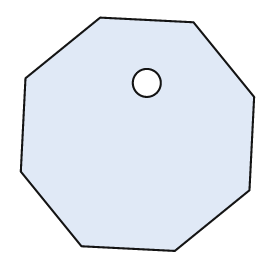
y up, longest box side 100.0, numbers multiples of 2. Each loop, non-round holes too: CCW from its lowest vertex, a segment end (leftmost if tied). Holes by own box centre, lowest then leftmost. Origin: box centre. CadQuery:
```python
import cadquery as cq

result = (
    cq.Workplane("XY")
    .moveTo(16.0, -50.0)
    .lineTo(48.0, -24.0)
    .lineTo(50.0, 16.0)
    .lineTo(24.0, 48.0)
    .lineTo(-16.0, 50.0)
    .lineTo(-48.0, 24.0)
    .lineTo(-50.0, -16.0)
    .lineTo(-24.0, -48.0)
    .close()
    .moveTo(4.0, 22.0)
    .circle(6.0)
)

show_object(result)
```